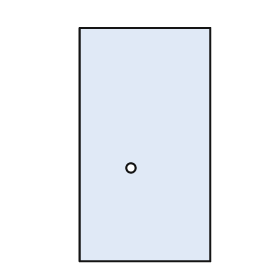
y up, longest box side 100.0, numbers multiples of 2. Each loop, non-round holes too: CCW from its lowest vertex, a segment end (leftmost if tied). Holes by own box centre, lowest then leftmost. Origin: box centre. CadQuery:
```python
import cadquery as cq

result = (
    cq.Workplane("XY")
    .moveTo(-28.0, -50.0)
    .lineTo(28.0, -50.0)
    .lineTo(28.0, 50.0)
    .lineTo(-28.0, 50.0)
    .close()
    .moveTo(-6.0, -10.0)
    .circle(2.0)
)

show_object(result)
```